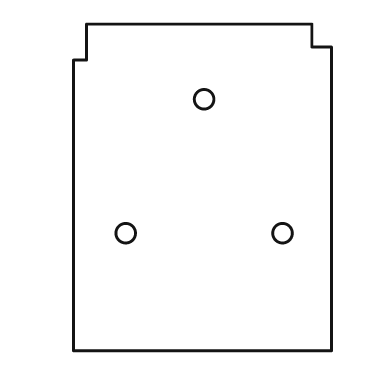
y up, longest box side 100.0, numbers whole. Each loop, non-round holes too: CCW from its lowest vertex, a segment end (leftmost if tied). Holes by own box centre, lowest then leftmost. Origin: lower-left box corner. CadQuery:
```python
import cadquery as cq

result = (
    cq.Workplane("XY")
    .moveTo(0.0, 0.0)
    .lineTo(79.0, 0.0)
    .lineTo(79.0, 93.0)
    .lineTo(73.0, 93.0)
    .lineTo(73.0, 100.0)
    .lineTo(4.0, 100.0)
    .lineTo(4.0, 89.0)
    .lineTo(0.0, 89.0)
    .close()
    .moveTo(16.0, 36.0)
    .circle(3.0)
    .moveTo(64.0, 36.0)
    .circle(3.0)
    .moveTo(40.0, 77.0)
    .circle(3.0)
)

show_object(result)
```